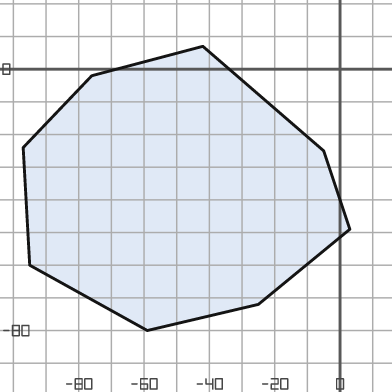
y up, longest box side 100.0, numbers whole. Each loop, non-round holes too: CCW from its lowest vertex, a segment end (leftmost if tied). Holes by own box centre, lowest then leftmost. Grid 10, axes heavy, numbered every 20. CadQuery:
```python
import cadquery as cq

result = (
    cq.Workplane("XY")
    .moveTo(-59.0, -80.0)
    .lineTo(-25.0, -72.0)
    .lineTo(3.0, -49.0)
    .lineTo(-5.0, -25.0)
    .lineTo(-42.0, 7.0)
    .lineTo(-76.0, -2.0)
    .lineTo(-97.0, -24.0)
    .lineTo(-95.0, -60.0)
    .close()
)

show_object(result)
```